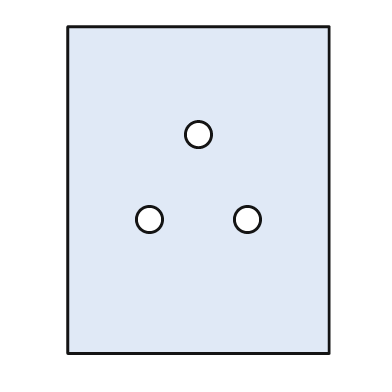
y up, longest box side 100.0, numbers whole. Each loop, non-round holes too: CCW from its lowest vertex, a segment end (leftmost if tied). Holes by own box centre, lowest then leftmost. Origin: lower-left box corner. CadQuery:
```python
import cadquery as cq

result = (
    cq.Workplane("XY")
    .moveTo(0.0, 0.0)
    .lineTo(80.0, 0.0)
    .lineTo(80.0, 100.0)
    .lineTo(0.0, 100.0)
    .close()
    .moveTo(25.0, 41.0)
    .circle(4.0)
    .moveTo(55.0, 41.0)
    .circle(4.0)
    .moveTo(40.0, 67.0)
    .circle(4.0)
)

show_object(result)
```